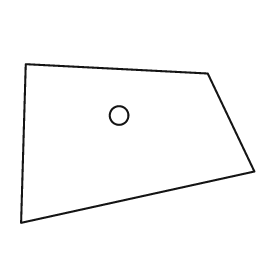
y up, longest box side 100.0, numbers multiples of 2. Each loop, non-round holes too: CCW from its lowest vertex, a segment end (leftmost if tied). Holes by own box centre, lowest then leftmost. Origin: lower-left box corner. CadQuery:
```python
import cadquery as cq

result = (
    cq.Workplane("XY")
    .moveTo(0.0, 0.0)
    .lineTo(100.0, 22.0)
    .lineTo(80.0, 64.0)
    .lineTo(2.0, 68.0)
    .close()
    .moveTo(42.0, 46.0)
    .circle(4.0)
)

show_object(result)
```